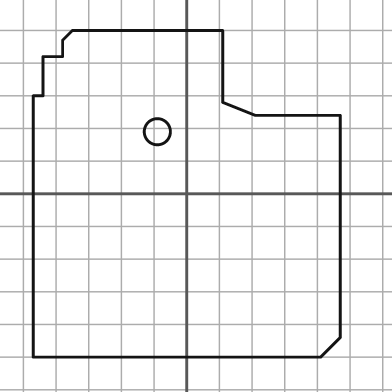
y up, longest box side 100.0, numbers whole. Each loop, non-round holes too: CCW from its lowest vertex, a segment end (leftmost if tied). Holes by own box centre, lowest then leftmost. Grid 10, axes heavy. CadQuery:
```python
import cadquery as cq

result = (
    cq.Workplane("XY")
    .moveTo(-47.0, -50.0)
    .lineTo(41.0, -50.0)
    .lineTo(47.0, -44.0)
    .lineTo(47.0, 24.0)
    .lineTo(21.0, 24.0)
    .lineTo(11.0, 28.0)
    .lineTo(11.0, 50.0)
    .lineTo(-35.0, 50.0)
    .lineTo(-38.0, 47.0)
    .lineTo(-38.0, 42.0)
    .lineTo(-44.0, 42.0)
    .lineTo(-44.0, 30.0)
    .lineTo(-47.0, 30.0)
    .close()
    .moveTo(-9.0, 19.0)
    .circle(4.0)
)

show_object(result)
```